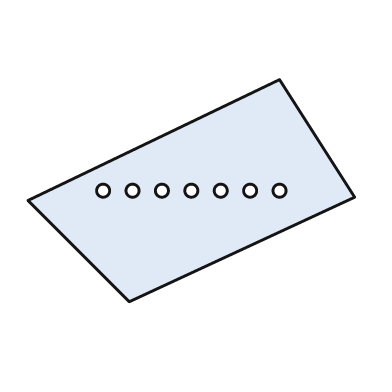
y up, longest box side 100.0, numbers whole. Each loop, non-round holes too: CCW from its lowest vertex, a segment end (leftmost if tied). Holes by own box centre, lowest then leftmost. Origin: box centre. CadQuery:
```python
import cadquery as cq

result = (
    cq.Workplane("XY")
    .moveTo(-19.0, -34.0)
    .lineTo(50.0, -2.0)
    .lineTo(27.0, 34.0)
    .lineTo(-50.0, -3.0)
    .close()
    .moveTo(-27.0, 0.0)
    .circle(2.0)
    .moveTo(-18.0, 0.0)
    .circle(2.0)
    .moveTo(-9.0, 0.0)
    .circle(2.0)
    .moveTo(0.0, 0.0)
    .circle(2.0)
    .moveTo(9.0, 0.0)
    .circle(2.0)
    .moveTo(18.0, 0.0)
    .circle(2.0)
    .moveTo(27.0, 0.0)
    .circle(2.0)
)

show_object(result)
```